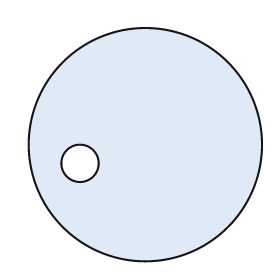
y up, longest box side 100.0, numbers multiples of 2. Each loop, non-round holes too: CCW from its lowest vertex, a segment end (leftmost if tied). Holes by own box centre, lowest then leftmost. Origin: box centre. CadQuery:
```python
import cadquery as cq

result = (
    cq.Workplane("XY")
    .moveTo(0.0, 0.0)
    .circle(50.0)
    .moveTo(-28.0, -8.0)
    .circle(8.0)
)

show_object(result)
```